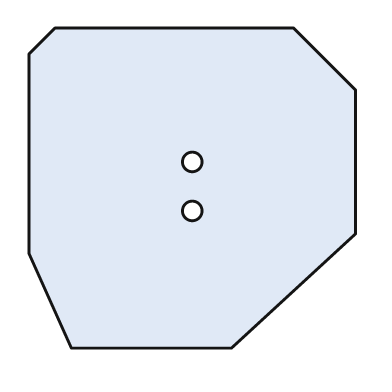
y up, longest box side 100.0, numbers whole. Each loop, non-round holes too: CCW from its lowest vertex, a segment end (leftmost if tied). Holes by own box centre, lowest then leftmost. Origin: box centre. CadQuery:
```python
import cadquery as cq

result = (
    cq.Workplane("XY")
    .moveTo(-37.0, -49.0)
    .lineTo(12.0, -49.0)
    .lineTo(50.0, -14.0)
    .lineTo(50.0, 30.0)
    .lineTo(31.0, 49.0)
    .lineTo(-42.0, 49.0)
    .lineTo(-50.0, 41.0)
    .lineTo(-50.0, -20.0)
    .close()
    .moveTo(0.0, -7.0)
    .circle(3.0)
    .moveTo(0.0, 8.0)
    .circle(3.0)
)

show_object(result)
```